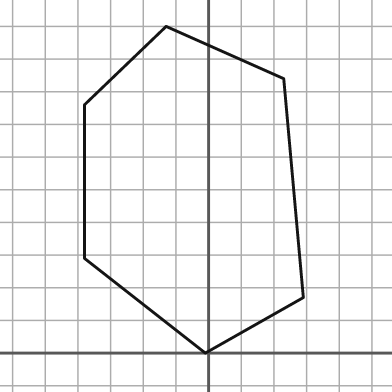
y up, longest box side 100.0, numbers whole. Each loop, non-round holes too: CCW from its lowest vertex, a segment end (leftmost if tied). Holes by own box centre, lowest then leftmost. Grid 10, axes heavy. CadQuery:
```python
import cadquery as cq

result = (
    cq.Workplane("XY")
    .moveTo(-1.0, 0.0)
    .lineTo(29.0, 17.0)
    .lineTo(23.0, 84.0)
    .lineTo(-13.0, 100.0)
    .lineTo(-38.0, 76.0)
    .lineTo(-38.0, 29.0)
    .close()
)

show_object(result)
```